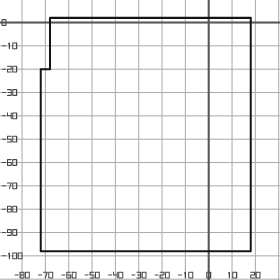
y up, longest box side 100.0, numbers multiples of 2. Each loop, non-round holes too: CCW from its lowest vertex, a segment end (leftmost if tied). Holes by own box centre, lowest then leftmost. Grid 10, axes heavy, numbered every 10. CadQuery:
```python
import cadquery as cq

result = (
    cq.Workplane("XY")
    .moveTo(-72.0, -98.0)
    .lineTo(18.0, -98.0)
    .lineTo(18.0, 2.0)
    .lineTo(-68.0, 2.0)
    .lineTo(-68.0, -20.0)
    .lineTo(-72.0, -20.0)
    .close()
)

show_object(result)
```